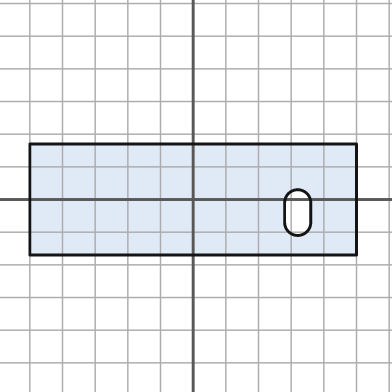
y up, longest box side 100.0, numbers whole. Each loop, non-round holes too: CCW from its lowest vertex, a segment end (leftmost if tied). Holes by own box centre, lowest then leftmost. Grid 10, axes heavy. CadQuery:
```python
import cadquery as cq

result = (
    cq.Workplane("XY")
    .moveTo(-50.0, -17.0)
    .lineTo(50.0, -17.0)
    .lineTo(50.0, 17.0)
    .lineTo(-50.0, 17.0)
    .close()
    .moveTo(28.0, -7.0)
    .threePointArc((32.0, -11.0), (36.0, -7.0))
    .lineTo(36.0, -1.0)
    .threePointArc((32.0, 3.0), (28.0, -1.0))
    .close()
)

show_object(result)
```